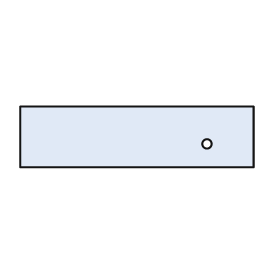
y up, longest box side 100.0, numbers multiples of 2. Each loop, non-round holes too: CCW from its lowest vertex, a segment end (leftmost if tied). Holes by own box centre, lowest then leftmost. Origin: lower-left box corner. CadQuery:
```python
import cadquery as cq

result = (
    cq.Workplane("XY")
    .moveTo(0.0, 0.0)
    .lineTo(100.0, 0.0)
    .lineTo(100.0, 26.0)
    .lineTo(0.0, 26.0)
    .close()
    .moveTo(80.0, 10.0)
    .circle(2.0)
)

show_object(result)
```